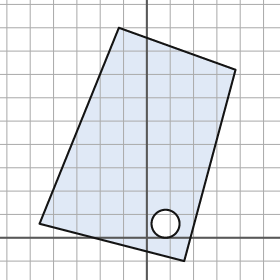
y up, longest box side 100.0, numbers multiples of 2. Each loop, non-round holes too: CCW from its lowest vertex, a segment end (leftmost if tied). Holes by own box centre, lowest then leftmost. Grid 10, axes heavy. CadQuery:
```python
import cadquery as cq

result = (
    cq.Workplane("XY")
    .moveTo(16.0, -10.0)
    .lineTo(38.0, 72.0)
    .lineTo(-12.0, 90.0)
    .lineTo(-46.0, 6.0)
    .close()
    .moveTo(8.0, 6.0)
    .circle(6.0)
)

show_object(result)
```